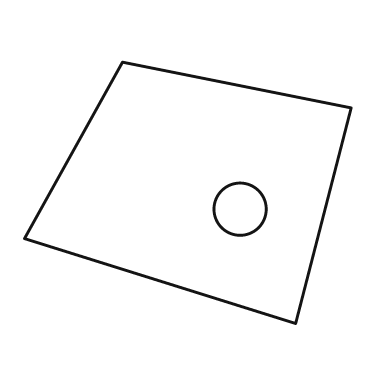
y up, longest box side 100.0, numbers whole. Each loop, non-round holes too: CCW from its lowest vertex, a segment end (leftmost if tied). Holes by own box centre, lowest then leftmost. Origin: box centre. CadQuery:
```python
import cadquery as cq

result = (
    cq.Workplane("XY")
    .moveTo(33.0, -40.0)
    .lineTo(50.0, 26.0)
    .lineTo(-20.0, 40.0)
    .lineTo(-50.0, -14.0)
    .close()
    .moveTo(16.0, -5.0)
    .circle(8.0)
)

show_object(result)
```